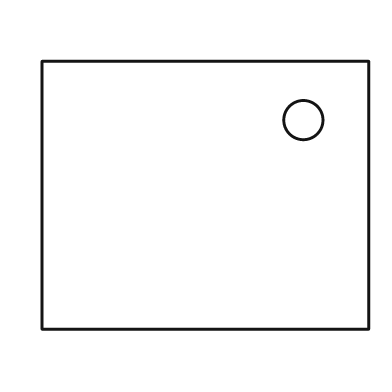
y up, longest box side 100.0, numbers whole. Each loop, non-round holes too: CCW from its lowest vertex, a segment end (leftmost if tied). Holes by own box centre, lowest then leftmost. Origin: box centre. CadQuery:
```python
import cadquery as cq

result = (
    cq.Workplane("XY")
    .moveTo(-50.0, -41.0)
    .lineTo(50.0, -41.0)
    .lineTo(50.0, 41.0)
    .lineTo(-50.0, 41.0)
    .close()
    .moveTo(30.0, 23.0)
    .circle(6.0)
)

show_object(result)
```